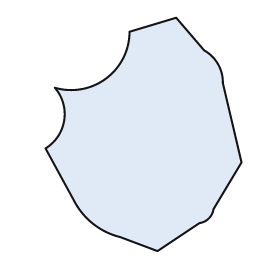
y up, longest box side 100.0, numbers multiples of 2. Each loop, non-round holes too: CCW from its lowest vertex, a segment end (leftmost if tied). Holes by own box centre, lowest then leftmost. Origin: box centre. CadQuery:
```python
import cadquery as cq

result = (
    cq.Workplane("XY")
    .moveTo(6.0, -50.0)
    .lineTo(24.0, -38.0)
    .threePointArc((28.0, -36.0), (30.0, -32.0))
    .lineTo(42.0, -12.0)
    .lineTo(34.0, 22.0)
    .threePointArc((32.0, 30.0), (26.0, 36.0))
    .lineTo(14.0, 50.0)
    .lineTo(-6.0, 44.0)
    .threePointArc((-16.0, 24.0), (-38.0, 20.0))
    .threePointArc((-34.0, 6.0), (-42.0, -6.0))
    .lineTo(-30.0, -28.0)
    .threePointArc((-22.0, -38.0), (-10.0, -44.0))
    .close()
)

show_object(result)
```